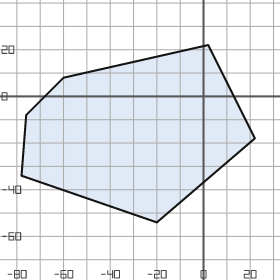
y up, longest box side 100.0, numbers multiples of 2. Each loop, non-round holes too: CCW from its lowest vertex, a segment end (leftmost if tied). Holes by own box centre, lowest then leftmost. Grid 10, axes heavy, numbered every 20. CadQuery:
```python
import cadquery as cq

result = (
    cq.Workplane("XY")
    .moveTo(-20.0, -54.0)
    .lineTo(22.0, -18.0)
    .lineTo(2.0, 22.0)
    .lineTo(-60.0, 8.0)
    .lineTo(-76.0, -8.0)
    .lineTo(-78.0, -34.0)
    .close()
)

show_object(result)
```